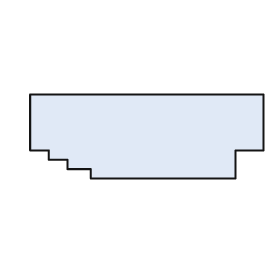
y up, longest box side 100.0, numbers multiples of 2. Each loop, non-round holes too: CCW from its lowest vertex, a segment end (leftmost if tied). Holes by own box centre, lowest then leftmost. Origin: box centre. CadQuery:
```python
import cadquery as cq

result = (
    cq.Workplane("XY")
    .moveTo(-24.0, -18.0)
    .lineTo(38.0, -18.0)
    .lineTo(38.0, -6.0)
    .lineTo(50.0, -6.0)
    .lineTo(50.0, 18.0)
    .lineTo(-50.0, 18.0)
    .lineTo(-50.0, -6.0)
    .lineTo(-42.0, -6.0)
    .lineTo(-42.0, -10.0)
    .lineTo(-34.0, -10.0)
    .lineTo(-34.0, -14.0)
    .lineTo(-24.0, -14.0)
    .close()
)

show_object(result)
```